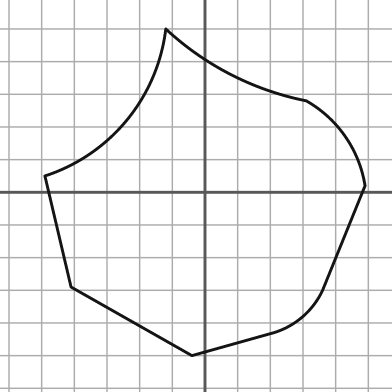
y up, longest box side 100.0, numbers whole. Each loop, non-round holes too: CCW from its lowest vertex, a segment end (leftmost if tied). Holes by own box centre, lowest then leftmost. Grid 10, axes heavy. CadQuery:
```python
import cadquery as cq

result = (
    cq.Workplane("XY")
    .moveTo(-4.0, -50.0)
    .lineTo(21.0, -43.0)
    .threePointArc((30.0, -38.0), (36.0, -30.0))
    .lineTo(49.0, 2.0)
    .threePointArc((43.0, 17.0), (31.0, 28.0))
    .threePointArc((8.0, 36.0), (-12.0, 50.0))
    .threePointArc((-24.0, 22.0), (-49.0, 5.0))
    .lineTo(-41.0, -29.0)
    .close()
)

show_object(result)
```